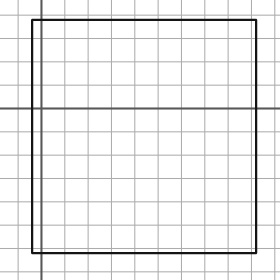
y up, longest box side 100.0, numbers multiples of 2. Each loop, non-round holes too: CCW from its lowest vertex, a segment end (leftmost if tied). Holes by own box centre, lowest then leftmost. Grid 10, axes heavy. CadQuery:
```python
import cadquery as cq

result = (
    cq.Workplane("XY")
    .moveTo(-4.0, -62.0)
    .lineTo(92.0, -62.0)
    .lineTo(92.0, 38.0)
    .lineTo(-4.0, 38.0)
    .close()
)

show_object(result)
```